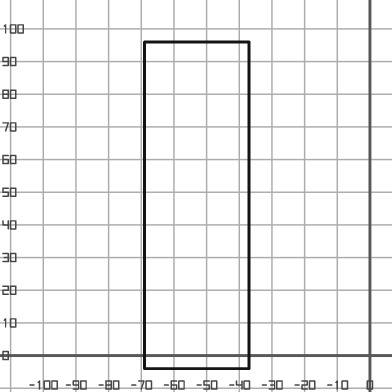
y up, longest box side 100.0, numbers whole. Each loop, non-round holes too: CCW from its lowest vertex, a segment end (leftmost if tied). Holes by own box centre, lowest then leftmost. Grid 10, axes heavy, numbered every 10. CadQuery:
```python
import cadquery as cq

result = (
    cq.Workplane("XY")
    .moveTo(-69.0, -4.0)
    .lineTo(-37.0, -4.0)
    .lineTo(-37.0, 96.0)
    .lineTo(-69.0, 96.0)
    .close()
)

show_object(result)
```